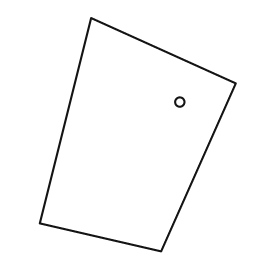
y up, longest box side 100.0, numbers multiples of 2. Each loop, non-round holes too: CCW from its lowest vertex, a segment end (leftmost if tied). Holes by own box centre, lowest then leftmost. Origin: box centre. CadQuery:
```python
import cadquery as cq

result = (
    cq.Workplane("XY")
    .moveTo(10.0, -50.0)
    .lineTo(42.0, 22.0)
    .lineTo(-20.0, 50.0)
    .lineTo(-42.0, -38.0)
    .close()
    .moveTo(18.0, 14.0)
    .circle(2.0)
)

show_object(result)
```